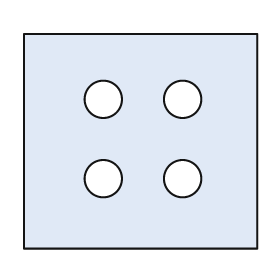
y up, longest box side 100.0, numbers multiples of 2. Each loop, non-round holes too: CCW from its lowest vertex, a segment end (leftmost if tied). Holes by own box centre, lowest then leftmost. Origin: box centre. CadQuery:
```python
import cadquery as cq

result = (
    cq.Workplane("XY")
    .moveTo(-50.0, -46.0)
    .lineTo(50.0, -46.0)
    .lineTo(50.0, 46.0)
    .lineTo(-50.0, 46.0)
    .close()
    .moveTo(-16.0, -16.0)
    .circle(8.0)
    .moveTo(18.0, -16.0)
    .circle(8.0)
    .moveTo(-16.0, 18.0)
    .circle(8.0)
    .moveTo(18.0, 18.0)
    .circle(8.0)
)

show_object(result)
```